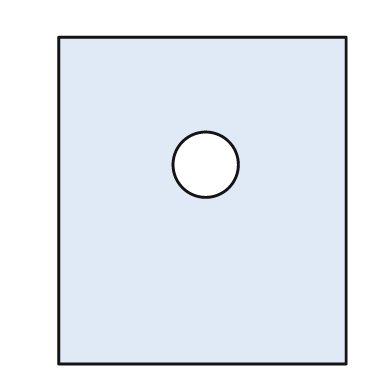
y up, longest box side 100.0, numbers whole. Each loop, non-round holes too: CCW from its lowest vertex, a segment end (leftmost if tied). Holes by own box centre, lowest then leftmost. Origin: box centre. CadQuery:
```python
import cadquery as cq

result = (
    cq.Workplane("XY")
    .moveTo(-44.0, -50.0)
    .lineTo(44.0, -50.0)
    .lineTo(44.0, 50.0)
    .lineTo(-44.0, 50.0)
    .close()
    .moveTo(1.0, 11.0)
    .circle(10.0)
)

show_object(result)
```